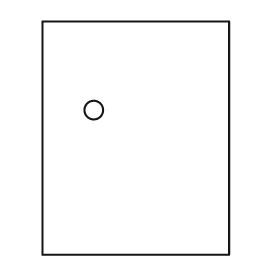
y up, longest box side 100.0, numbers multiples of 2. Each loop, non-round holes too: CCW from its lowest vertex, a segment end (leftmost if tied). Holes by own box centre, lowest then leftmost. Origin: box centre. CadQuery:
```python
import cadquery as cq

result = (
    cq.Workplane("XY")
    .moveTo(-40.0, -50.0)
    .lineTo(40.0, -50.0)
    .lineTo(40.0, 50.0)
    .lineTo(-40.0, 50.0)
    .close()
    .moveTo(-18.0, 12.0)
    .circle(4.0)
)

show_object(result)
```